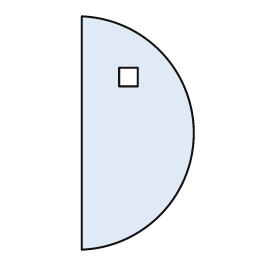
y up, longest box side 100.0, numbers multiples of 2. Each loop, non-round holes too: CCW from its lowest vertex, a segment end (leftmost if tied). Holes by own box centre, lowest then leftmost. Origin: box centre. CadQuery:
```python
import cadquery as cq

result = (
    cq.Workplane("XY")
    .moveTo(-24.0, -50.0)
    .threePointArc((24.0, 0.0), (-24.0, 50.0))
    .close()
    .moveTo(-8.0, 20.0)
    .lineTo(0.0, 20.0)
    .lineTo(0.0, 28.0)
    .lineTo(-8.0, 28.0)
    .close()
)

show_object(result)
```